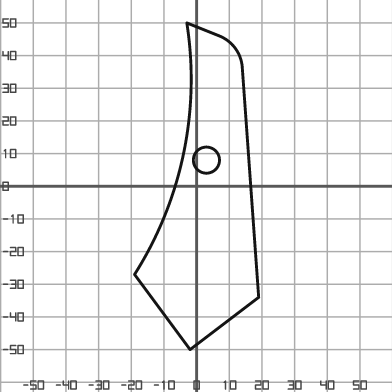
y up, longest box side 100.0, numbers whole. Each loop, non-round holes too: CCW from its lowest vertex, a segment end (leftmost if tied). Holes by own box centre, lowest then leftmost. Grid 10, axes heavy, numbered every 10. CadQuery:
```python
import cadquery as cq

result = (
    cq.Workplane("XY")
    .moveTo(-2.0, -50.0)
    .lineTo(19.0, -34.0)
    .lineTo(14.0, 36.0)
    .threePointArc((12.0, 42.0), (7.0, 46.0))
    .lineTo(-3.0, 50.0)
    .threePointArc((-4.0, 10.0), (-19.0, -27.0))
    .close()
    .moveTo(3.0, 8.0)
    .circle(4.0)
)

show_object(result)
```